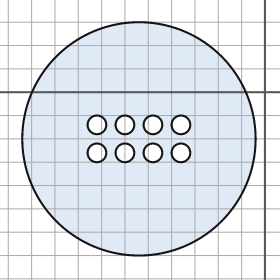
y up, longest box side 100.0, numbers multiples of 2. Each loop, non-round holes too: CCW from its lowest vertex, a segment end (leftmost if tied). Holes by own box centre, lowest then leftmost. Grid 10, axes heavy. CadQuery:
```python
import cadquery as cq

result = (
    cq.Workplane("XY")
    .moveTo(-54.0, -20.0)
    .circle(50.0)
    .moveTo(-72.0, -26.0)
    .circle(4.0)
    .moveTo(-60.0, -26.0)
    .circle(4.0)
    .moveTo(-48.0, -26.0)
    .circle(4.0)
    .moveTo(-36.0, -26.0)
    .circle(4.0)
    .moveTo(-72.0, -14.0)
    .circle(4.0)
    .moveTo(-60.0, -14.0)
    .circle(4.0)
    .moveTo(-48.0, -14.0)
    .circle(4.0)
    .moveTo(-36.0, -14.0)
    .circle(4.0)
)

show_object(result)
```